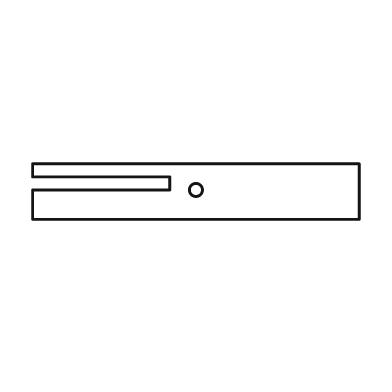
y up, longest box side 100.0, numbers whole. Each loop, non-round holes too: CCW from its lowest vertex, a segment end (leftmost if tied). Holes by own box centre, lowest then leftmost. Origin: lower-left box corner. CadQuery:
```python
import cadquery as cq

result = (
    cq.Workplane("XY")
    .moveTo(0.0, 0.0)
    .lineTo(100.0, 0.0)
    .lineTo(100.0, 17.0)
    .lineTo(0.0, 17.0)
    .lineTo(0.0, 13.0)
    .lineTo(42.0, 13.0)
    .lineTo(42.0, 9.0)
    .lineTo(0.0, 9.0)
    .close()
    .moveTo(50.0, 9.0)
    .circle(2.0)
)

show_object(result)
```